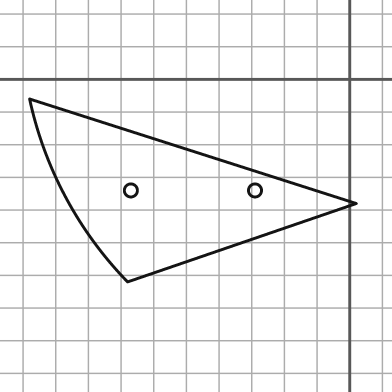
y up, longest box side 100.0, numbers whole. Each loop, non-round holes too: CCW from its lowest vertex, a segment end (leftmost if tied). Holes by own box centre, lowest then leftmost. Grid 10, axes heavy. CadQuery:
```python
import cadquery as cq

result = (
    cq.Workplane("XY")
    .moveTo(-68.0, -62.0)
    .lineTo(2.0, -38.0)
    .lineTo(-98.0, -6.0)
    .threePointArc((-87.0, -36.0), (-68.0, -62.0))
    .close()
    .moveTo(-67.0, -34.0)
    .circle(2.0)
    .moveTo(-29.0, -34.0)
    .circle(2.0)
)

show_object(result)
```